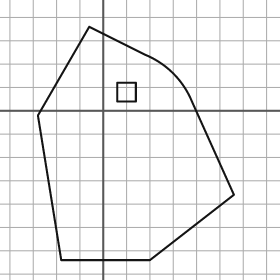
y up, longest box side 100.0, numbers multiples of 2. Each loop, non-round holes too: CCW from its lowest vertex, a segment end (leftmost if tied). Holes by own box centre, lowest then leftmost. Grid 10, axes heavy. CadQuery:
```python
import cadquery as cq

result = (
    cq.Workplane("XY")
    .moveTo(-18.0, -64.0)
    .lineTo(20.0, -64.0)
    .lineTo(56.0, -36.0)
    .lineTo(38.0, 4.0)
    .threePointArc((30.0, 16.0), (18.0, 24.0))
    .lineTo(-6.0, 36.0)
    .lineTo(-28.0, -2.0)
    .close()
    .moveTo(6.0, 4.0)
    .lineTo(14.0, 4.0)
    .lineTo(14.0, 12.0)
    .lineTo(6.0, 12.0)
    .close()
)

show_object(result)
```